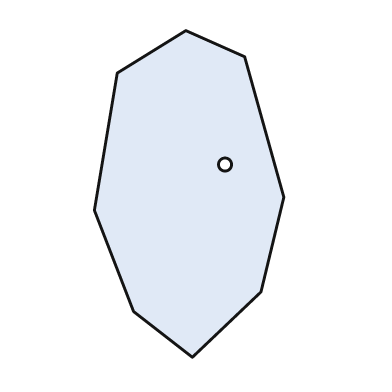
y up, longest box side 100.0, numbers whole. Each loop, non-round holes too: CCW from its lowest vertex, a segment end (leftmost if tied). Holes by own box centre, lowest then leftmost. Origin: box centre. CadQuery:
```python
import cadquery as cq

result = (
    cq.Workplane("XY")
    .moveTo(1.0, -50.0)
    .lineTo(22.0, -30.0)
    .lineTo(29.0, -1.0)
    .lineTo(17.0, 42.0)
    .lineTo(-1.0, 50.0)
    .lineTo(-22.0, 37.0)
    .lineTo(-29.0, -5.0)
    .lineTo(-17.0, -36.0)
    .close()
    .moveTo(11.0, 9.0)
    .circle(2.0)
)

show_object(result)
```